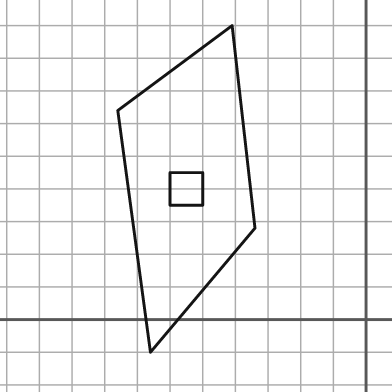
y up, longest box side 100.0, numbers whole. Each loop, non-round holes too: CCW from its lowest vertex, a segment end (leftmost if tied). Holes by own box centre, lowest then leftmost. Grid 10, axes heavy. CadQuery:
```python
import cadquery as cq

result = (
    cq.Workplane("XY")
    .moveTo(-66.0, -10.0)
    .lineTo(-34.0, 28.0)
    .lineTo(-41.0, 90.0)
    .lineTo(-76.0, 64.0)
    .close()
    .moveTo(-60.0, 35.0)
    .lineTo(-50.0, 35.0)
    .lineTo(-50.0, 45.0)
    .lineTo(-60.0, 45.0)
    .close()
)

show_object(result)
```